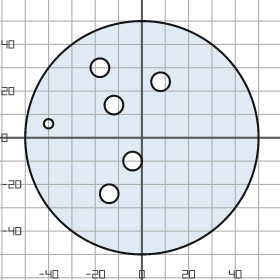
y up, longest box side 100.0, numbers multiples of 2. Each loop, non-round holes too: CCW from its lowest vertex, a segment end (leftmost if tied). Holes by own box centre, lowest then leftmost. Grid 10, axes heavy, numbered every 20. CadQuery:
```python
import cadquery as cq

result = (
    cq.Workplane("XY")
    .moveTo(0.0, 0.0)
    .circle(50.0)
    .moveTo(-14.0, -24.0)
    .circle(4.0)
    .moveTo(-4.0, -10.0)
    .circle(4.0)
    .moveTo(-40.0, 6.0)
    .circle(2.0)
    .moveTo(-12.0, 14.0)
    .circle(4.0)
    .moveTo(8.0, 24.0)
    .circle(4.0)
    .moveTo(-18.0, 30.0)
    .circle(4.0)
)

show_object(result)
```